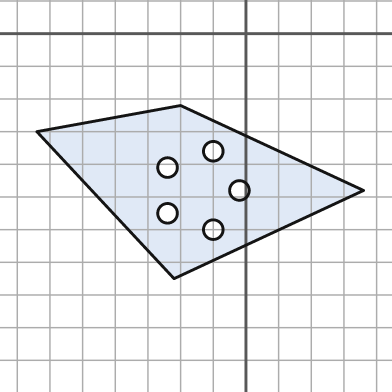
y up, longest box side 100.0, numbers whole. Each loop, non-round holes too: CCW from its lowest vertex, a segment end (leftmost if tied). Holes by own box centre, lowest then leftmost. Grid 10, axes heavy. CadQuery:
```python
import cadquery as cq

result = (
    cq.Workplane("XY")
    .moveTo(-22.0, -75.0)
    .lineTo(36.0, -48.0)
    .lineTo(-20.0, -22.0)
    .lineTo(-64.0, -30.0)
    .close()
    .moveTo(-10.0, -60.0)
    .circle(3.0)
    .moveTo(-24.0, -55.0)
    .circle(3.0)
    .moveTo(-2.0, -48.0)
    .circle(3.0)
    .moveTo(-24.0, -41.0)
    .circle(3.0)
    .moveTo(-10.0, -36.0)
    .circle(3.0)
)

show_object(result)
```